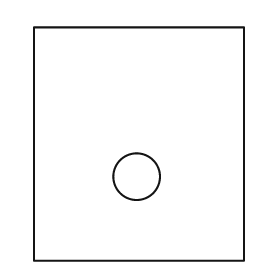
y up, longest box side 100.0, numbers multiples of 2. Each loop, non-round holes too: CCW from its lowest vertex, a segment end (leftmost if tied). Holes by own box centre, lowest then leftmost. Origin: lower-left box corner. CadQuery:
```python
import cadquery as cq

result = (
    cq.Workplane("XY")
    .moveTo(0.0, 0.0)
    .lineTo(90.0, 0.0)
    .lineTo(90.0, 100.0)
    .lineTo(0.0, 100.0)
    .close()
    .moveTo(44.0, 36.0)
    .circle(10.0)
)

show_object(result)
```